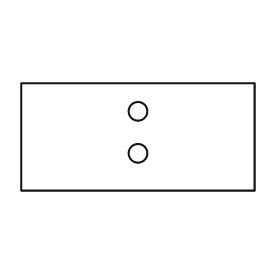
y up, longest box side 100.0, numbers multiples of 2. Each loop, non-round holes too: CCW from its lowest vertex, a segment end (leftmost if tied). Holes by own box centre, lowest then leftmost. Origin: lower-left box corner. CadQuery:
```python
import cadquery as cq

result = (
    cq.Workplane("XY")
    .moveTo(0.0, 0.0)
    .lineTo(100.0, 0.0)
    .lineTo(100.0, 46.0)
    .lineTo(0.0, 46.0)
    .close()
    .moveTo(50.0, 16.0)
    .circle(4.0)
    .moveTo(50.0, 34.0)
    .circle(4.0)
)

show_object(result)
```